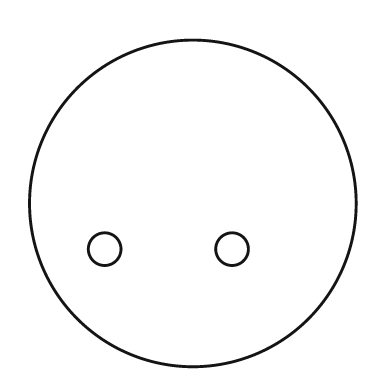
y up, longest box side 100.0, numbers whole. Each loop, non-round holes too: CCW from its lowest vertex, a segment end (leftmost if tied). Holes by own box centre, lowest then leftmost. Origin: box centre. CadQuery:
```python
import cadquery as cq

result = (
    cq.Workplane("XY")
    .moveTo(0.0, 0.0)
    .circle(50.0)
    .moveTo(-27.0, -14.0)
    .circle(5.0)
    .moveTo(12.0, -14.0)
    .circle(5.0)
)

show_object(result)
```